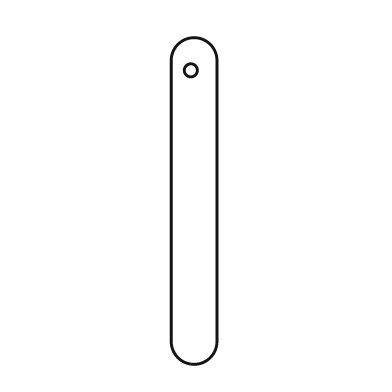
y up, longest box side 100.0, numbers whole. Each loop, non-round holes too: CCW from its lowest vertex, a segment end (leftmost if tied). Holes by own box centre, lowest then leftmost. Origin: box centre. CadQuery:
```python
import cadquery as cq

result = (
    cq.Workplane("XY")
    .moveTo(-7.0, -43.0)
    .threePointArc((0.0, -50.0), (7.0, -43.0))
    .lineTo(7.0, 43.0)
    .threePointArc((0.0, 50.0), (-7.0, 43.0))
    .close()
    .moveTo(-1.0, 40.0)
    .circle(2.0)
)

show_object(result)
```